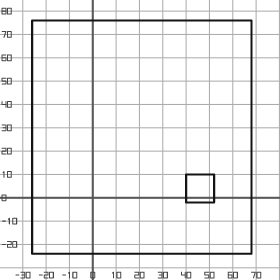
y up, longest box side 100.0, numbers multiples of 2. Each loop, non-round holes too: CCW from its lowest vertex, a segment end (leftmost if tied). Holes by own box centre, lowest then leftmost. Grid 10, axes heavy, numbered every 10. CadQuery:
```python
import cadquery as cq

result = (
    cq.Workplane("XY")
    .moveTo(-26.0, -24.0)
    .lineTo(68.0, -24.0)
    .lineTo(68.0, 76.0)
    .lineTo(-26.0, 76.0)
    .close()
    .moveTo(40.0, -2.0)
    .lineTo(52.0, -2.0)
    .lineTo(52.0, 10.0)
    .lineTo(40.0, 10.0)
    .close()
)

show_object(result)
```